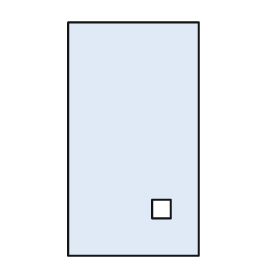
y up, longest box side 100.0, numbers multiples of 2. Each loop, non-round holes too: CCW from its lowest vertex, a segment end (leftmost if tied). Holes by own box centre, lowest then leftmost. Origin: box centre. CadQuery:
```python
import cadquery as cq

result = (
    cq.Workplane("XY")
    .moveTo(-28.0, -50.0)
    .lineTo(28.0, -50.0)
    .lineTo(28.0, 50.0)
    .lineTo(-28.0, 50.0)
    .close()
    .moveTo(8.0, -34.0)
    .lineTo(16.0, -34.0)
    .lineTo(16.0, -26.0)
    .lineTo(8.0, -26.0)
    .close()
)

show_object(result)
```